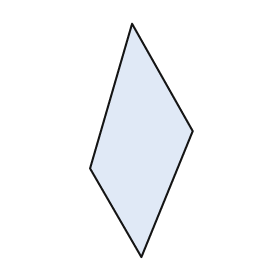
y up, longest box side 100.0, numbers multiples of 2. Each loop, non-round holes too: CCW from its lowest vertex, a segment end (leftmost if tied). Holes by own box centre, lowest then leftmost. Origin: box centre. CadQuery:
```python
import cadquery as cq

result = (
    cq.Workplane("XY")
    .moveTo(0.0, -50.0)
    .lineTo(22.0, 4.0)
    .lineTo(-4.0, 50.0)
    .lineTo(-22.0, -12.0)
    .close()
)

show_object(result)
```